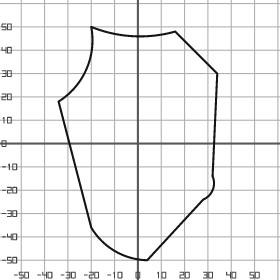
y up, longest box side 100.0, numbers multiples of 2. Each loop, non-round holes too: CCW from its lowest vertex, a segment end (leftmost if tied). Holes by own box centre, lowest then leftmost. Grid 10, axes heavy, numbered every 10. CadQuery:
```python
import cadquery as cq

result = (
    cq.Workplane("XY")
    .moveTo(4.0, -50.0)
    .lineTo(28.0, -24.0)
    .threePointArc((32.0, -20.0), (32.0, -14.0))
    .lineTo(34.0, 30.0)
    .lineTo(16.0, 48.0)
    .threePointArc((-2.0, 46.0), (-20.0, 50.0))
    .threePointArc((-22.0, 32.0), (-34.0, 18.0))
    .lineTo(-20.0, -36.0)
    .threePointArc((-10.0, -46.0), (4.0, -50.0))
    .close()
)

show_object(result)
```